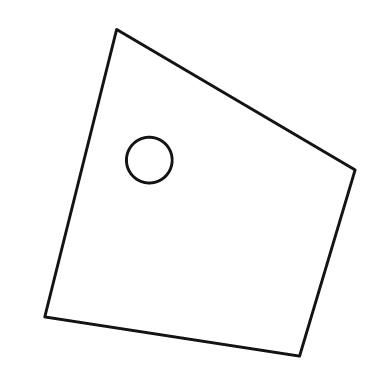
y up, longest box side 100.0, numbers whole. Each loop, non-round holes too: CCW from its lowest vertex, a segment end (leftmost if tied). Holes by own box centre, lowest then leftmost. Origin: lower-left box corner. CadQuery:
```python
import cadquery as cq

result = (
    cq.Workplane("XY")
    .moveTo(78.0, 0.0)
    .lineTo(95.0, 57.0)
    .lineTo(22.0, 100.0)
    .lineTo(0.0, 12.0)
    .close()
    .moveTo(32.0, 60.0)
    .circle(7.0)
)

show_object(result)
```